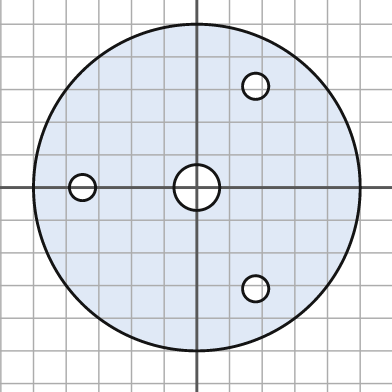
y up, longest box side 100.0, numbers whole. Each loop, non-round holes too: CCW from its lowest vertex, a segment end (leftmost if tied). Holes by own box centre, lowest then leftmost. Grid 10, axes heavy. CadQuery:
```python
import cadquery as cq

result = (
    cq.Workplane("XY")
    .moveTo(0.0, 0.0)
    .circle(50.0)
    .moveTo(18.0, -31.0)
    .circle(4.0)
    .moveTo(-35.0, 0.0)
    .circle(4.0)
    .moveTo(0.0, 0.0)
    .circle(7.0)
    .moveTo(18.0, 31.0)
    .circle(4.0)
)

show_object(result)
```